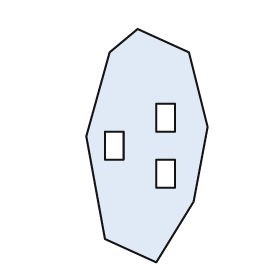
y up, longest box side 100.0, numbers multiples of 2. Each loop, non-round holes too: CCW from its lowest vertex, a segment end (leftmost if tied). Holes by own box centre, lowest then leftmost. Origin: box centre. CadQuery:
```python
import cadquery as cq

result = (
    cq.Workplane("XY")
    .moveTo(4.0, -50.0)
    .lineTo(20.0, -24.0)
    .lineTo(26.0, 8.0)
    .lineTo(18.0, 40.0)
    .lineTo(-4.0, 50.0)
    .lineTo(-16.0, 40.0)
    .lineTo(-26.0, 4.0)
    .lineTo(-18.0, -40.0)
    .close()
    .moveTo(4.0, -18.0)
    .lineTo(12.0, -18.0)
    .lineTo(12.0, -6.0)
    .lineTo(4.0, -6.0)
    .close()
    .moveTo(-18.0, -6.0)
    .lineTo(-10.0, -6.0)
    .lineTo(-10.0, 6.0)
    .lineTo(-18.0, 6.0)
    .close()
    .moveTo(4.0, 6.0)
    .lineTo(12.0, 6.0)
    .lineTo(12.0, 18.0)
    .lineTo(4.0, 18.0)
    .close()
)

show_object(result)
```